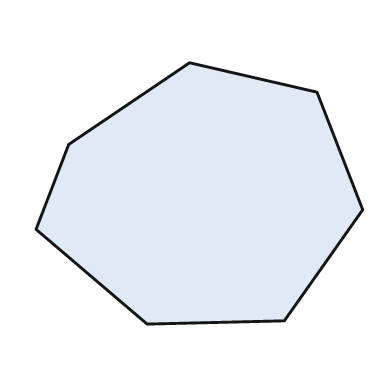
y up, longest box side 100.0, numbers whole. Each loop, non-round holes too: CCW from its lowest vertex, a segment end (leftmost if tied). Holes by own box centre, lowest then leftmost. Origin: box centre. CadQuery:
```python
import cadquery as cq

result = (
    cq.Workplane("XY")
    .moveTo(-16.0, -40.0)
    .lineTo(26.0, -39.0)
    .lineTo(50.0, -5.0)
    .lineTo(36.0, 31.0)
    .lineTo(-3.0, 40.0)
    .lineTo(-40.0, 15.0)
    .lineTo(-50.0, -11.0)
    .close()
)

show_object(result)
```